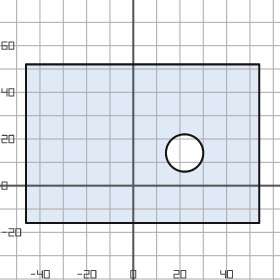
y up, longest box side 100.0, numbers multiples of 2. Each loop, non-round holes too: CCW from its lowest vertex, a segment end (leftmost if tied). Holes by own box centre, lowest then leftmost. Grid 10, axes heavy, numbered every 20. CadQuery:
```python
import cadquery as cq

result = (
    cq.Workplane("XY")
    .moveTo(-46.0, -16.0)
    .lineTo(54.0, -16.0)
    .lineTo(54.0, 52.0)
    .lineTo(-46.0, 52.0)
    .close()
    .moveTo(22.0, 14.0)
    .circle(8.0)
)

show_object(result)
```